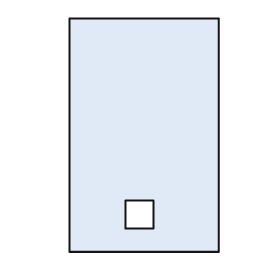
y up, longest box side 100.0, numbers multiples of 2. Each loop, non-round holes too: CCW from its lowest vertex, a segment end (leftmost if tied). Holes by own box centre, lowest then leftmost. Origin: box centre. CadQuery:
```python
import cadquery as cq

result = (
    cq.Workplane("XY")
    .moveTo(-32.0, -50.0)
    .lineTo(32.0, -50.0)
    .lineTo(32.0, 50.0)
    .lineTo(-32.0, 50.0)
    .close()
    .moveTo(-8.0, -40.0)
    .lineTo(4.0, -40.0)
    .lineTo(4.0, -28.0)
    .lineTo(-8.0, -28.0)
    .close()
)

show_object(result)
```